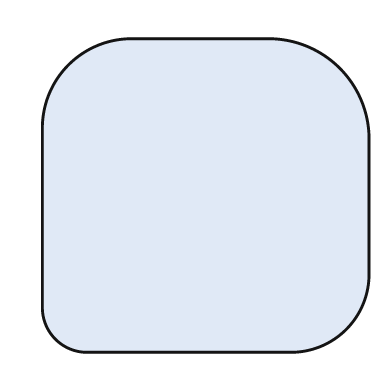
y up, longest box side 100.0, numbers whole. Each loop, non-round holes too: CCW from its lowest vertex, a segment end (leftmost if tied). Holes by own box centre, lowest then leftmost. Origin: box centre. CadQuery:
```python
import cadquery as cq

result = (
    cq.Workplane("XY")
    .moveTo(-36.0, -48.0)
    .lineTo(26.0, -48.0)
    .threePointArc((43.0, -41.0), (50.0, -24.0))
    .lineTo(50.0, 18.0)
    .threePointArc((41.0, 39.0), (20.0, 48.0))
    .lineTo(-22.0, 48.0)
    .threePointArc((-42.0, 40.0), (-50.0, 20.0))
    .lineTo(-50.0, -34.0)
    .threePointArc((-46.0, -44.0), (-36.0, -48.0))
    .close()
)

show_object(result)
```